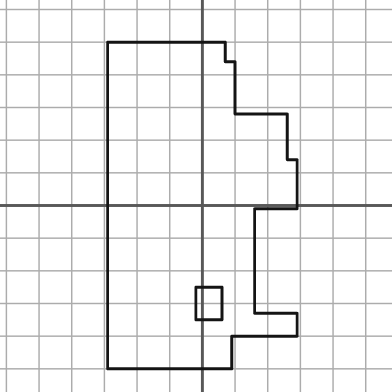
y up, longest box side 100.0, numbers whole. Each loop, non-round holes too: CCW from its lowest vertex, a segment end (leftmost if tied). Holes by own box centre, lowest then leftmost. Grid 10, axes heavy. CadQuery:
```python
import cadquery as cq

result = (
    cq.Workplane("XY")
    .moveTo(-29.0, -50.0)
    .lineTo(9.0, -50.0)
    .lineTo(9.0, -40.0)
    .lineTo(29.0, -40.0)
    .lineTo(29.0, -33.0)
    .lineTo(16.0, -33.0)
    .lineTo(16.0, -1.0)
    .lineTo(29.0, -1.0)
    .lineTo(29.0, 14.0)
    .lineTo(26.0, 14.0)
    .lineTo(26.0, 28.0)
    .lineTo(10.0, 28.0)
    .lineTo(10.0, 44.0)
    .lineTo(7.0, 44.0)
    .lineTo(7.0, 50.0)
    .lineTo(-29.0, 50.0)
    .close()
    .moveTo(-2.0, -35.0)
    .lineTo(6.0, -35.0)
    .lineTo(6.0, -25.0)
    .lineTo(-2.0, -25.0)
    .close()
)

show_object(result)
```